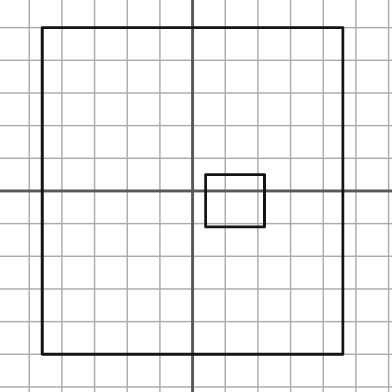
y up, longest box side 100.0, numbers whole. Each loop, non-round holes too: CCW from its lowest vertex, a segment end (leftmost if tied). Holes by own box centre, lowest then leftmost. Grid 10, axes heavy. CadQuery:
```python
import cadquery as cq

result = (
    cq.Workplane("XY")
    .moveTo(-46.0, -50.0)
    .lineTo(46.0, -50.0)
    .lineTo(46.0, 50.0)
    .lineTo(-46.0, 50.0)
    .close()
    .moveTo(4.0, -11.0)
    .lineTo(22.0, -11.0)
    .lineTo(22.0, 5.0)
    .lineTo(4.0, 5.0)
    .close()
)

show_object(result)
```